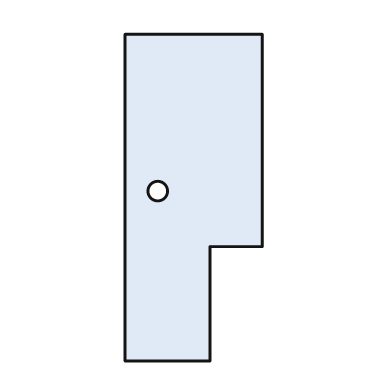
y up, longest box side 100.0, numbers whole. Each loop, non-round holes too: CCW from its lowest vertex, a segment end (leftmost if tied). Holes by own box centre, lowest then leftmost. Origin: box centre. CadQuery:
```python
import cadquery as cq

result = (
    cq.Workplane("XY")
    .moveTo(-21.0, -50.0)
    .lineTo(5.0, -50.0)
    .lineTo(5.0, -15.0)
    .lineTo(21.0, -15.0)
    .lineTo(21.0, 50.0)
    .lineTo(-21.0, 50.0)
    .close()
    .moveTo(-11.0, 2.0)
    .circle(3.0)
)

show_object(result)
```